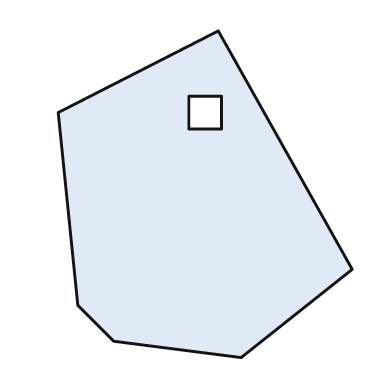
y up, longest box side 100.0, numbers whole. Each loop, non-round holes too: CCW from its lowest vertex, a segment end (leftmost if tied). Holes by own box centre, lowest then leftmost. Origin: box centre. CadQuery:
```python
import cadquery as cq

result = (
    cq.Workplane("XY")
    .moveTo(11.0, -50.0)
    .lineTo(45.0, -23.0)
    .lineTo(4.0, 50.0)
    .lineTo(-45.0, 25.0)
    .lineTo(-39.0, -34.0)
    .lineTo(-28.0, -45.0)
    .close()
    .moveTo(-5.0, 20.0)
    .lineTo(5.0, 20.0)
    .lineTo(5.0, 30.0)
    .lineTo(-5.0, 30.0)
    .close()
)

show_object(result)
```